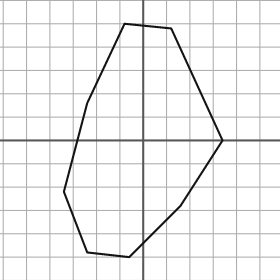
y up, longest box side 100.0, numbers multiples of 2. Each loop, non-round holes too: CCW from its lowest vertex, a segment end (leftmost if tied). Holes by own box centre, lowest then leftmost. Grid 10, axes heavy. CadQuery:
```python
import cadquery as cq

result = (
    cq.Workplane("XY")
    .moveTo(-6.0, -50.0)
    .lineTo(16.0, -28.0)
    .lineTo(34.0, 0.0)
    .lineTo(12.0, 48.0)
    .lineTo(-8.0, 50.0)
    .lineTo(-24.0, 16.0)
    .lineTo(-34.0, -22.0)
    .lineTo(-24.0, -48.0)
    .close()
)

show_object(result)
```